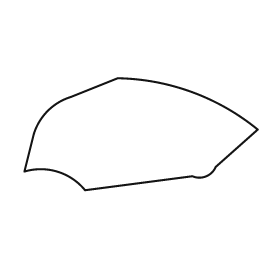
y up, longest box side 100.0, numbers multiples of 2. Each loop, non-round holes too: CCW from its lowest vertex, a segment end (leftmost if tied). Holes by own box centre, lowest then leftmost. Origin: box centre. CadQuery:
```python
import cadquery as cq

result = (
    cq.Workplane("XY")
    .moveTo(-24.0, -24.0)
    .lineTo(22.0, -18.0)
    .threePointArc((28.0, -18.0), (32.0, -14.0))
    .lineTo(50.0, 2.0)
    .threePointArc((22.0, 18.0), (-10.0, 24.0))
    .lineTo(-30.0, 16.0)
    .threePointArc((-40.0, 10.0), (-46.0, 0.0))
    .lineTo(-50.0, -16.0)
    .threePointArc((-36.0, -16.0), (-24.0, -24.0))
    .close()
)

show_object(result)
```